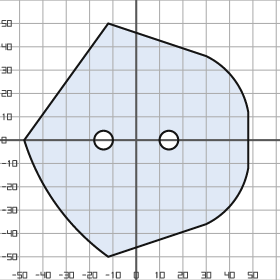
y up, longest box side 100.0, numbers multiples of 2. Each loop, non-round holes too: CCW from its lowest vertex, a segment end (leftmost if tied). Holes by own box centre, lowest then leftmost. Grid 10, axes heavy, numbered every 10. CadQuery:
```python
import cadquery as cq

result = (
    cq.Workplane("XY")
    .moveTo(-12.0, -50.0)
    .lineTo(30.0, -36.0)
    .threePointArc((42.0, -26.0), (48.0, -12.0))
    .lineTo(48.0, 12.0)
    .threePointArc((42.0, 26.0), (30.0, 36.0))
    .lineTo(-12.0, 50.0)
    .lineTo(-48.0, 0.0)
    .threePointArc((-34.0, -28.0), (-12.0, -50.0))
    .close()
    .moveTo(-14.0, 0.0)
    .circle(4.0)
    .moveTo(14.0, 0.0)
    .circle(4.0)
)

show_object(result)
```